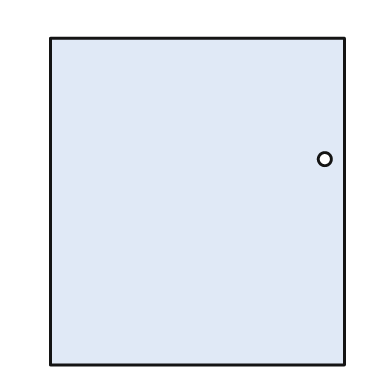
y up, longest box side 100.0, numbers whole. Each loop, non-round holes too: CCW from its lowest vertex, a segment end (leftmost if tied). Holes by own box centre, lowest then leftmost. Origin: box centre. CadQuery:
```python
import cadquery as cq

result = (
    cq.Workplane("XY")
    .moveTo(-45.0, -50.0)
    .lineTo(45.0, -50.0)
    .lineTo(45.0, 50.0)
    .lineTo(-45.0, 50.0)
    .close()
    .moveTo(39.0, 13.0)
    .circle(2.0)
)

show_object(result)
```